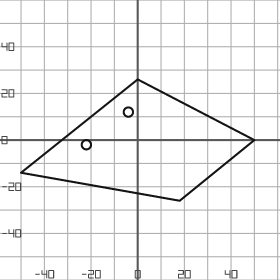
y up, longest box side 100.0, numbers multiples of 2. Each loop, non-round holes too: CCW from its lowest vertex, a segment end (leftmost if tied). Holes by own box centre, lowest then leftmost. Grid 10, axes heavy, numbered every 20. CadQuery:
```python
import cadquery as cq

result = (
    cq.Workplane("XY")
    .moveTo(18.0, -26.0)
    .lineTo(50.0, 0.0)
    .lineTo(0.0, 26.0)
    .lineTo(-50.0, -14.0)
    .close()
    .moveTo(-22.0, -2.0)
    .circle(2.0)
    .moveTo(-4.0, 12.0)
    .circle(2.0)
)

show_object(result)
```